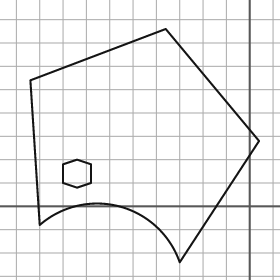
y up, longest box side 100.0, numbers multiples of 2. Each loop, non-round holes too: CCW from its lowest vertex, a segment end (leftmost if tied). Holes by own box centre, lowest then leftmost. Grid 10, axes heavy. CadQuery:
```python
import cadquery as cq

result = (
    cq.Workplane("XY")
    .moveTo(-30.0, -24.0)
    .lineTo(4.0, 28.0)
    .lineTo(-36.0, 76.0)
    .lineTo(-94.0, 54.0)
    .lineTo(-90.0, -8.0)
    .threePointArc((-56.0, 0.0), (-30.0, -24.0))
    .close()
    .moveTo(-74.0, 8.0)
    .lineTo(-68.0, 10.0)
    .lineTo(-68.0, 18.0)
    .lineTo(-74.0, 20.0)
    .lineTo(-80.0, 18.0)
    .lineTo(-80.0, 10.0)
    .close()
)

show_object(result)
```